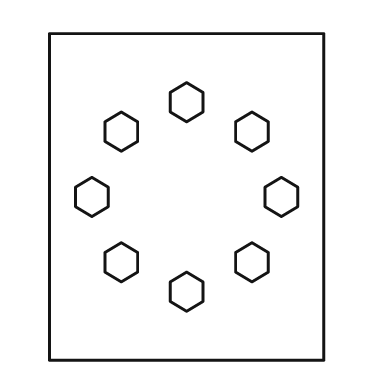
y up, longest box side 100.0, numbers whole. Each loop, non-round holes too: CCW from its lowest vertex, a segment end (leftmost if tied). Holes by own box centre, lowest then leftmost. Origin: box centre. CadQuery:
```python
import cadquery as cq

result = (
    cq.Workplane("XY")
    .moveTo(-42.0, -50.0)
    .lineTo(42.0, -50.0)
    .lineTo(42.0, 50.0)
    .lineTo(-42.0, 50.0)
    .close()
    .moveTo(0.0, -35.0)
    .lineTo(5.0, -32.0)
    .lineTo(5.0, -26.0)
    .lineTo(0.0, -23.0)
    .lineTo(-5.0, -26.0)
    .lineTo(-5.0, -32.0)
    .close()
    .moveTo(-20.0, -26.0)
    .lineTo(-15.0, -23.0)
    .lineTo(-15.0, -17.0)
    .lineTo(-20.0, -14.0)
    .lineTo(-25.0, -17.0)
    .lineTo(-25.0, -23.0)
    .close()
    .moveTo(20.0, -26.0)
    .lineTo(25.0, -23.0)
    .lineTo(25.0, -17.0)
    .lineTo(20.0, -14.0)
    .lineTo(15.0, -17.0)
    .lineTo(15.0, -23.0)
    .close()
    .moveTo(-29.0, -6.0)
    .lineTo(-24.0, -3.0)
    .lineTo(-24.0, 3.0)
    .lineTo(-29.0, 6.0)
    .lineTo(-34.0, 3.0)
    .lineTo(-34.0, -3.0)
    .close()
    .moveTo(29.0, -6.0)
    .lineTo(34.0, -3.0)
    .lineTo(34.0, 3.0)
    .lineTo(29.0, 6.0)
    .lineTo(24.0, 3.0)
    .lineTo(24.0, -3.0)
    .close()
    .moveTo(-20.0, 14.0)
    .lineTo(-15.0, 17.0)
    .lineTo(-15.0, 23.0)
    .lineTo(-20.0, 26.0)
    .lineTo(-25.0, 23.0)
    .lineTo(-25.0, 17.0)
    .close()
    .moveTo(20.0, 14.0)
    .lineTo(25.0, 17.0)
    .lineTo(25.0, 23.0)
    .lineTo(20.0, 26.0)
    .lineTo(15.0, 23.0)
    .lineTo(15.0, 17.0)
    .close()
    .moveTo(0.0, 23.0)
    .lineTo(5.0, 26.0)
    .lineTo(5.0, 32.0)
    .lineTo(0.0, 35.0)
    .lineTo(-5.0, 32.0)
    .lineTo(-5.0, 26.0)
    .close()
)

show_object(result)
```